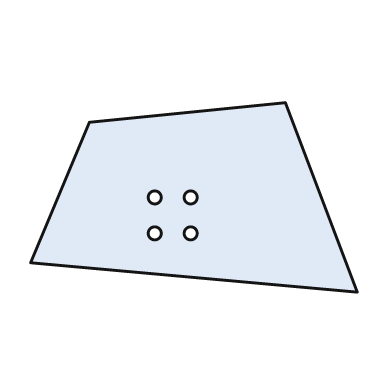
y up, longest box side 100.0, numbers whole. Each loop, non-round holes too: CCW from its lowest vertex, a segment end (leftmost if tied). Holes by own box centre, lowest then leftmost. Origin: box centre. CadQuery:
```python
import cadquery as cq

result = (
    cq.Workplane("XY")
    .moveTo(50.0, -29.0)
    .lineTo(28.0, 29.0)
    .lineTo(-32.0, 23.0)
    .lineTo(-50.0, -20.0)
    .close()
    .moveTo(-12.0, -11.0)
    .circle(2.0)
    .moveTo(-1.0, -11.0)
    .circle(2.0)
    .moveTo(-12.0, 0.0)
    .circle(2.0)
    .moveTo(-1.0, 0.0)
    .circle(2.0)
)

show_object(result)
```